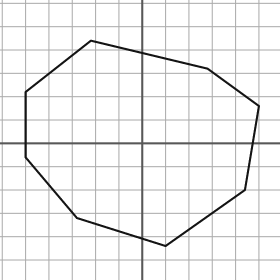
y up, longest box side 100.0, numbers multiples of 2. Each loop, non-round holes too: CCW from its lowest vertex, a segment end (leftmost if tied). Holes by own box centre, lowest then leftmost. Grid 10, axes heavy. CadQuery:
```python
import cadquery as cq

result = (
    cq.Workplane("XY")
    .moveTo(10.0, -44.0)
    .lineTo(44.0, -20.0)
    .lineTo(50.0, 16.0)
    .lineTo(28.0, 32.0)
    .lineTo(-22.0, 44.0)
    .lineTo(-50.0, 22.0)
    .lineTo(-50.0, -6.0)
    .lineTo(-28.0, -32.0)
    .close()
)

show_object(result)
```